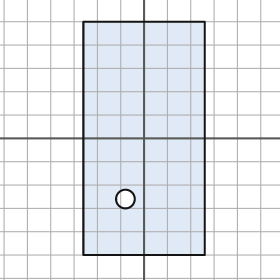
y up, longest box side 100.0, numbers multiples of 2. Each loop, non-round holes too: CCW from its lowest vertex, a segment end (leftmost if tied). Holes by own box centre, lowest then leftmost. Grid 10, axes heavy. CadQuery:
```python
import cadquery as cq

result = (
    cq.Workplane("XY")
    .moveTo(-26.0, -50.0)
    .lineTo(26.0, -50.0)
    .lineTo(26.0, 50.0)
    .lineTo(-26.0, 50.0)
    .close()
    .moveTo(-8.0, -26.0)
    .circle(4.0)
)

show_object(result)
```